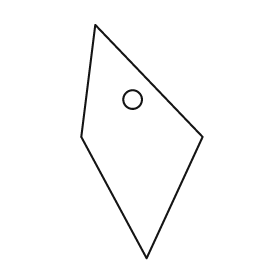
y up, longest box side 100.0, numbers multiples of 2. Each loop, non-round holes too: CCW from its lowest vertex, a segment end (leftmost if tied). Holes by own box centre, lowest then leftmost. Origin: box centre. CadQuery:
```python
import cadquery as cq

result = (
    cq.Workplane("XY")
    .moveTo(2.0, -50.0)
    .lineTo(26.0, 2.0)
    .lineTo(-20.0, 50.0)
    .lineTo(-26.0, 2.0)
    .close()
    .moveTo(-4.0, 18.0)
    .circle(4.0)
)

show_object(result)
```